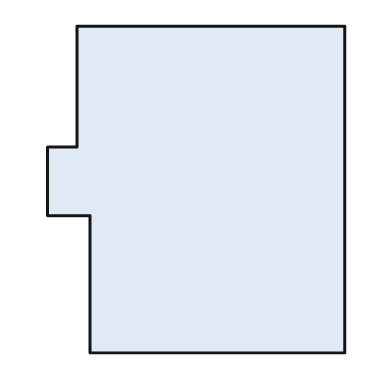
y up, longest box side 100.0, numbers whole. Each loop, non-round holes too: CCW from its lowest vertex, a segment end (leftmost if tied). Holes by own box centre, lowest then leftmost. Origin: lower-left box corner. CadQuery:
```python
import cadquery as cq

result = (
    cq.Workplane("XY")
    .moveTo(13.0, 0.0)
    .lineTo(91.0, 0.0)
    .lineTo(91.0, 100.0)
    .lineTo(9.0, 100.0)
    .lineTo(9.0, 63.0)
    .lineTo(0.0, 63.0)
    .lineTo(0.0, 42.0)
    .lineTo(13.0, 42.0)
    .close()
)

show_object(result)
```